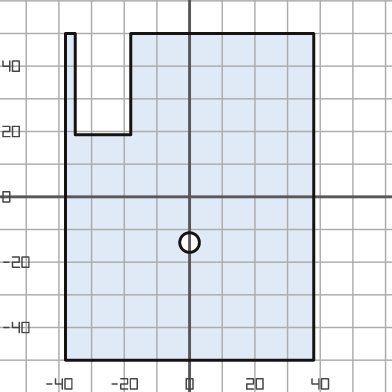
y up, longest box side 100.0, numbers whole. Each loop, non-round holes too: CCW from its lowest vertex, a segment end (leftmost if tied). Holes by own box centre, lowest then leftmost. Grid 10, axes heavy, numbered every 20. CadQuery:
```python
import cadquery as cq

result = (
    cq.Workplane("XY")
    .moveTo(-38.0, -50.0)
    .lineTo(38.0, -50.0)
    .lineTo(38.0, 50.0)
    .lineTo(-18.0, 50.0)
    .lineTo(-18.0, 19.0)
    .lineTo(-35.0, 19.0)
    .lineTo(-35.0, 50.0)
    .lineTo(-38.0, 50.0)
    .close()
    .moveTo(0.0, -14.0)
    .circle(3.0)
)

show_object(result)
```